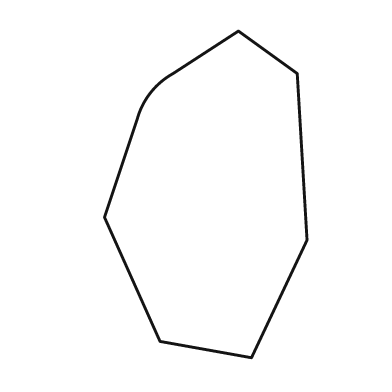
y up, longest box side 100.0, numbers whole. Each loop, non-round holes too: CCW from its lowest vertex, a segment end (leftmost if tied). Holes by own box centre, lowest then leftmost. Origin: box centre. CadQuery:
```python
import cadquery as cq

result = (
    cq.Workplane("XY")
    .moveTo(14.0, -50.0)
    .lineTo(31.0, -14.0)
    .lineTo(28.0, 37.0)
    .lineTo(10.0, 50.0)
    .lineTo(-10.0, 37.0)
    .threePointArc((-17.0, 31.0), (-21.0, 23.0))
    .lineTo(-31.0, -7.0)
    .lineTo(-14.0, -45.0)
    .close()
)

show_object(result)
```